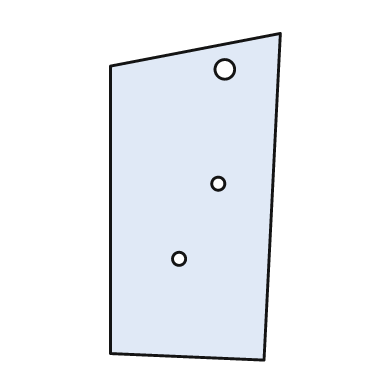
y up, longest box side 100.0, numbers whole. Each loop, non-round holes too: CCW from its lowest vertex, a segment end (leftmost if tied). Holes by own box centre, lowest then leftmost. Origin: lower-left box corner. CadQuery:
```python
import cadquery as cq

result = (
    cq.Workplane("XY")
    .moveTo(47.0, 0.0)
    .lineTo(52.0, 100.0)
    .lineTo(0.0, 90.0)
    .lineTo(0.0, 2.0)
    .close()
    .moveTo(21.0, 31.0)
    .circle(2.0)
    .moveTo(33.0, 54.0)
    .circle(2.0)
    .moveTo(35.0, 89.0)
    .circle(3.0)
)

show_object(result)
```